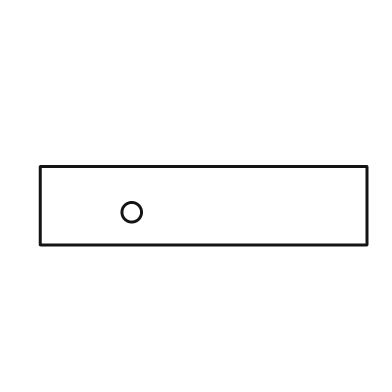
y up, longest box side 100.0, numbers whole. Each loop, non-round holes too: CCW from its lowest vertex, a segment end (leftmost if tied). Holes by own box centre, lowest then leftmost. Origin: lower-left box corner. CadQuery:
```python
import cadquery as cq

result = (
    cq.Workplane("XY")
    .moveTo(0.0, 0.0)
    .lineTo(100.0, 0.0)
    .lineTo(100.0, 24.0)
    .lineTo(0.0, 24.0)
    .close()
    .moveTo(28.0, 10.0)
    .circle(3.0)
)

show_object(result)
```